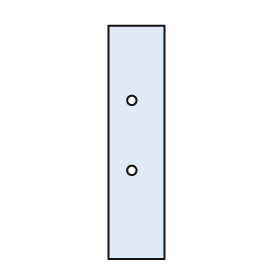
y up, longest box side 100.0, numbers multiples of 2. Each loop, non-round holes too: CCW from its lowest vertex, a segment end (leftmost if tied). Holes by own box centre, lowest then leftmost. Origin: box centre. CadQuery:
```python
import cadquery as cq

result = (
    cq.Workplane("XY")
    .moveTo(-12.0, -50.0)
    .lineTo(12.0, -50.0)
    .lineTo(12.0, 50.0)
    .lineTo(-12.0, 50.0)
    .close()
    .moveTo(-2.0, -12.0)
    .circle(2.0)
    .moveTo(-2.0, 18.0)
    .circle(2.0)
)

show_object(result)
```